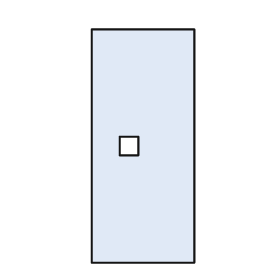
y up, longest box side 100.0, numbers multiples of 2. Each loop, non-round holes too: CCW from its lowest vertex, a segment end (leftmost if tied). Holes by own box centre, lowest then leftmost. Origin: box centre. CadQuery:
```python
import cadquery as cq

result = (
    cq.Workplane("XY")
    .moveTo(-22.0, -50.0)
    .lineTo(22.0, -50.0)
    .lineTo(22.0, 50.0)
    .lineTo(-22.0, 50.0)
    .close()
    .moveTo(-10.0, -4.0)
    .lineTo(-2.0, -4.0)
    .lineTo(-2.0, 4.0)
    .lineTo(-10.0, 4.0)
    .close()
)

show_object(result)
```